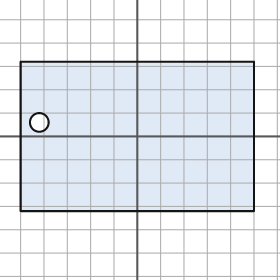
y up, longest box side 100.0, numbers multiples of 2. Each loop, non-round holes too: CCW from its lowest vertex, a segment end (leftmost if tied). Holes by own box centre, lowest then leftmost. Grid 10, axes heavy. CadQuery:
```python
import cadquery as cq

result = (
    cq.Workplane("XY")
    .moveTo(-50.0, -32.0)
    .lineTo(50.0, -32.0)
    .lineTo(50.0, 32.0)
    .lineTo(-50.0, 32.0)
    .close()
    .moveTo(-42.0, 6.0)
    .circle(4.0)
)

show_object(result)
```